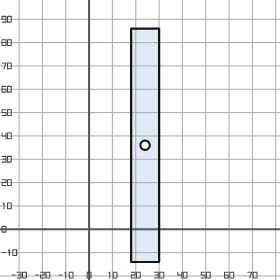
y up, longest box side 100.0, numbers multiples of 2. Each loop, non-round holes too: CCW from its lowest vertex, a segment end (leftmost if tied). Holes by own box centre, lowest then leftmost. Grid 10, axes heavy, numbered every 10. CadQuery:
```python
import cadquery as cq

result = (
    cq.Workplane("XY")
    .moveTo(18.0, -14.0)
    .lineTo(30.0, -14.0)
    .lineTo(30.0, 86.0)
    .lineTo(18.0, 86.0)
    .close()
    .moveTo(24.0, 36.0)
    .circle(2.0)
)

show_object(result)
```